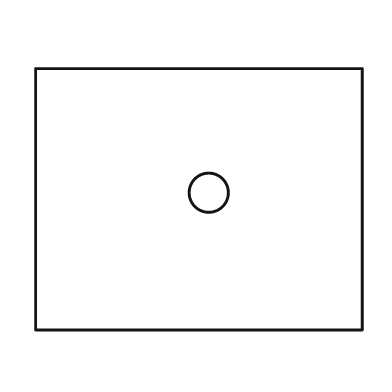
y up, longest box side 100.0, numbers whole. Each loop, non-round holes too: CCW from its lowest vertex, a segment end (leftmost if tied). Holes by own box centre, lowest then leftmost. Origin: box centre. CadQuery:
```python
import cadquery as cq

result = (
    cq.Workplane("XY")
    .moveTo(-50.0, -40.0)
    .lineTo(50.0, -40.0)
    .lineTo(50.0, 40.0)
    .lineTo(-50.0, 40.0)
    .close()
    .moveTo(3.0, 2.0)
    .circle(6.0)
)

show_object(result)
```